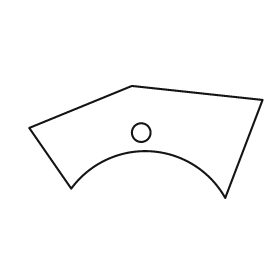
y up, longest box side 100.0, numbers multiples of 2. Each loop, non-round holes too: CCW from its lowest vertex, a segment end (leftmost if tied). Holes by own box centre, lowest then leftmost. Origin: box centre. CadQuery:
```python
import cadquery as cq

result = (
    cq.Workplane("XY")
    .moveTo(34.0, -24.0)
    .lineTo(50.0, 18.0)
    .lineTo(-6.0, 24.0)
    .lineTo(-50.0, 6.0)
    .lineTo(-32.0, -20.0)
    .threePointArc((2.0, -4.0), (34.0, -24.0))
    .close()
    .moveTo(-2.0, 4.0)
    .circle(4.0)
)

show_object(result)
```